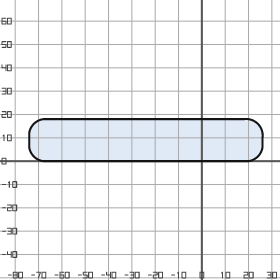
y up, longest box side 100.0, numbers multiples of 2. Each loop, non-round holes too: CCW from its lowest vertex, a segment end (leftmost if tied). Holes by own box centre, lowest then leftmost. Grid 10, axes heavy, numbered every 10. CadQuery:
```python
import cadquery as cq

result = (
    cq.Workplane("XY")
    .moveTo(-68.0, 0.0)
    .lineTo(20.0, 0.0)
    .threePointArc((24.0, 2.0), (26.0, 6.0))
    .lineTo(26.0, 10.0)
    .threePointArc((24.0, 16.0), (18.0, 18.0))
    .lineTo(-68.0, 18.0)
    .threePointArc((-72.0, 16.0), (-74.0, 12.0))
    .lineTo(-74.0, 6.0)
    .threePointArc((-72.0, 2.0), (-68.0, 0.0))
    .close()
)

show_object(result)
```